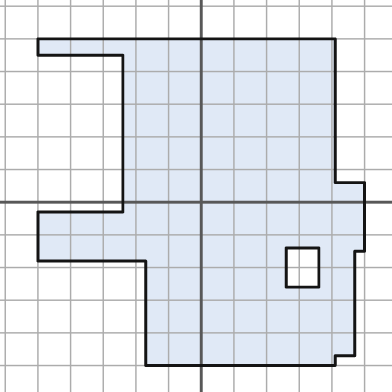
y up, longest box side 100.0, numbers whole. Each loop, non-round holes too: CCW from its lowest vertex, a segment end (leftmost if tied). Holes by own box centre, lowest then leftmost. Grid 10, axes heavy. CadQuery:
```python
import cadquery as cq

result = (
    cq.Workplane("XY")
    .moveTo(-17.0, -50.0)
    .lineTo(41.0, -50.0)
    .lineTo(41.0, -47.0)
    .lineTo(47.0, -47.0)
    .lineTo(47.0, -15.0)
    .lineTo(50.0, -15.0)
    .lineTo(50.0, 6.0)
    .lineTo(41.0, 6.0)
    .lineTo(41.0, 50.0)
    .lineTo(-50.0, 50.0)
    .lineTo(-50.0, 45.0)
    .lineTo(-24.0, 45.0)
    .lineTo(-24.0, -3.0)
    .lineTo(-50.0, -3.0)
    .lineTo(-50.0, -18.0)
    .lineTo(-17.0, -18.0)
    .close()
    .moveTo(26.0, -26.0)
    .lineTo(36.0, -26.0)
    .lineTo(36.0, -14.0)
    .lineTo(26.0, -14.0)
    .close()
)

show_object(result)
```